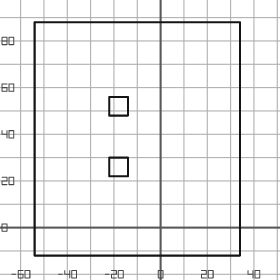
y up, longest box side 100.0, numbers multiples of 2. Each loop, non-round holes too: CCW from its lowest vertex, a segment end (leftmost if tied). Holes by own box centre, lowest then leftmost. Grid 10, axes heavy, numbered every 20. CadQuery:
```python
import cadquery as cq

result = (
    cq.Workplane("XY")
    .moveTo(-54.0, -12.0)
    .lineTo(34.0, -12.0)
    .lineTo(34.0, 88.0)
    .lineTo(-54.0, 88.0)
    .close()
    .moveTo(-22.0, 22.0)
    .lineTo(-14.0, 22.0)
    .lineTo(-14.0, 30.0)
    .lineTo(-22.0, 30.0)
    .close()
    .moveTo(-22.0, 48.0)
    .lineTo(-14.0, 48.0)
    .lineTo(-14.0, 56.0)
    .lineTo(-22.0, 56.0)
    .close()
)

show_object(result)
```